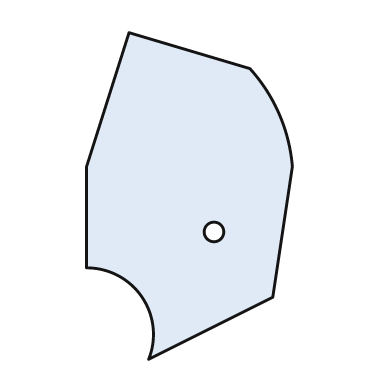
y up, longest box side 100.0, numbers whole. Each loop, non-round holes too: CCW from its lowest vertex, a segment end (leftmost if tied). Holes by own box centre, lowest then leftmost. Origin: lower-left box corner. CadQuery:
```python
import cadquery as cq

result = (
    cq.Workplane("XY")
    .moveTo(19.0, 0.0)
    .lineTo(57.0, 19.0)
    .lineTo(63.0, 59.0)
    .threePointArc((59.0, 75.0), (50.0, 89.0))
    .lineTo(13.0, 100.0)
    .lineTo(0.0, 59.0)
    .lineTo(0.0, 28.0)
    .threePointArc((17.0, 19.0), (19.0, 0.0))
    .close()
    .moveTo(39.0, 39.0)
    .circle(3.0)
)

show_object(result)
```